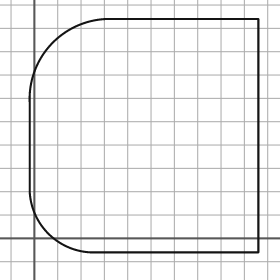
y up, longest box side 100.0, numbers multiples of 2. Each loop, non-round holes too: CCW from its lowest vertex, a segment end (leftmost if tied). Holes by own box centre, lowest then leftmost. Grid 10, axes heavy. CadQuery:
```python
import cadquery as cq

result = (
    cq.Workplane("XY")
    .moveTo(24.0, -6.0)
    .lineTo(96.0, -6.0)
    .lineTo(96.0, 94.0)
    .lineTo(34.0, 94.0)
    .threePointArc((8.0, 84.0), (-2.0, 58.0))
    .lineTo(-2.0, 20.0)
    .threePointArc((6.0, 2.0), (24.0, -6.0))
    .close()
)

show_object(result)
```